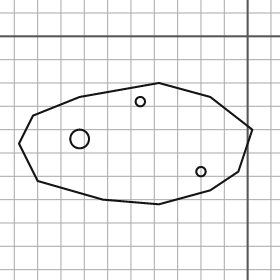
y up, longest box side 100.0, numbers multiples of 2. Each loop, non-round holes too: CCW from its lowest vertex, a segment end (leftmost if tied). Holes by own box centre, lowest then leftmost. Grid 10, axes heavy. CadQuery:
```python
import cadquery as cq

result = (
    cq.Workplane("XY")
    .moveTo(-38.0, -72.0)
    .lineTo(-16.0, -66.0)
    .lineTo(-4.0, -58.0)
    .lineTo(2.0, -40.0)
    .lineTo(-16.0, -26.0)
    .lineTo(-38.0, -20.0)
    .lineTo(-72.0, -26.0)
    .lineTo(-92.0, -34.0)
    .lineTo(-98.0, -46.0)
    .lineTo(-90.0, -62.0)
    .lineTo(-62.0, -70.0)
    .close()
    .moveTo(-20.0, -58.0)
    .circle(2.0)
    .moveTo(-72.0, -44.0)
    .circle(4.0)
    .moveTo(-46.0, -28.0)
    .circle(2.0)
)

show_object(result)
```